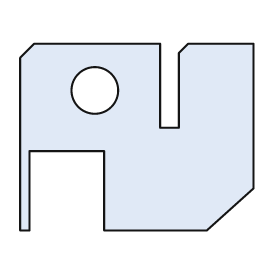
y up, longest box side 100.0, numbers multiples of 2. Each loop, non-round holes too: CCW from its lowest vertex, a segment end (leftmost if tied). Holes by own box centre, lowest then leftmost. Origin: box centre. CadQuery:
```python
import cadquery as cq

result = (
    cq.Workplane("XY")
    .moveTo(-50.0, -40.0)
    .lineTo(-46.0, -40.0)
    .lineTo(-46.0, -6.0)
    .lineTo(-14.0, -6.0)
    .lineTo(-14.0, -40.0)
    .lineTo(30.0, -40.0)
    .lineTo(50.0, -22.0)
    .lineTo(50.0, 40.0)
    .lineTo(22.0, 40.0)
    .lineTo(18.0, 36.0)
    .lineTo(18.0, 4.0)
    .lineTo(10.0, 4.0)
    .lineTo(10.0, 40.0)
    .lineTo(-44.0, 40.0)
    .lineTo(-50.0, 34.0)
    .close()
    .moveTo(-18.0, 20.0)
    .circle(10.0)
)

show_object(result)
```